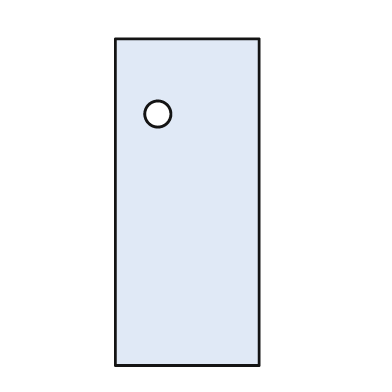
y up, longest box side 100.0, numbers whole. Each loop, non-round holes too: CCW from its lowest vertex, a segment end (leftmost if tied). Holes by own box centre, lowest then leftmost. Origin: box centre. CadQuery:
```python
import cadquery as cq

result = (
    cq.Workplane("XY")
    .moveTo(-22.0, -50.0)
    .lineTo(22.0, -50.0)
    .lineTo(22.0, 50.0)
    .lineTo(-22.0, 50.0)
    .close()
    .moveTo(-9.0, 27.0)
    .circle(4.0)
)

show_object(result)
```